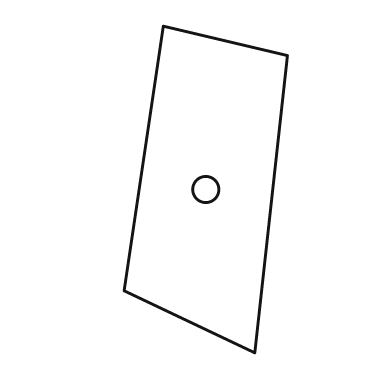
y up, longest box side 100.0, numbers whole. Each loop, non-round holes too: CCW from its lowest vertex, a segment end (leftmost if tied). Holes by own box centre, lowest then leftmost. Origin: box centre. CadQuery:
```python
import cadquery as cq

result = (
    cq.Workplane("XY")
    .moveTo(15.0, -50.0)
    .lineTo(25.0, 41.0)
    .lineTo(-13.0, 50.0)
    .lineTo(-25.0, -31.0)
    .close()
    .moveTo(0.0, 0.0)
    .circle(4.0)
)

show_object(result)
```